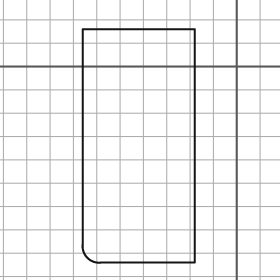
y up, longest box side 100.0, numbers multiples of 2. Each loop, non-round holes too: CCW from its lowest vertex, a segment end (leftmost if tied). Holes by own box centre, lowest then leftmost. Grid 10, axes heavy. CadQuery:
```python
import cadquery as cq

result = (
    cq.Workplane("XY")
    .moveTo(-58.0, -84.0)
    .lineTo(-18.0, -84.0)
    .lineTo(-18.0, 16.0)
    .lineTo(-66.0, 16.0)
    .lineTo(-66.0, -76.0)
    .threePointArc((-64.0, -82.0), (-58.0, -84.0))
    .close()
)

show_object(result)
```